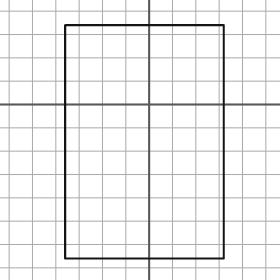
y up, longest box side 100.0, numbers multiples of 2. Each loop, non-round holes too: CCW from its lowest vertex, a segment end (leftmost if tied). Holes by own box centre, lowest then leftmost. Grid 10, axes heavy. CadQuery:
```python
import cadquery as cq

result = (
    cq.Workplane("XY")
    .moveTo(-36.0, -66.0)
    .lineTo(32.0, -66.0)
    .lineTo(32.0, 34.0)
    .lineTo(-36.0, 34.0)
    .close()
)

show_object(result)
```